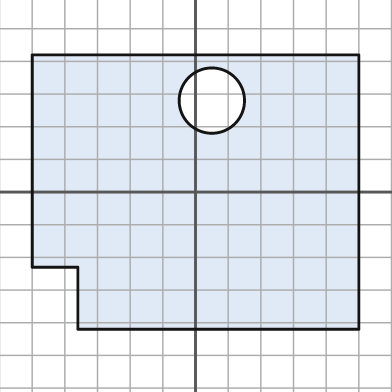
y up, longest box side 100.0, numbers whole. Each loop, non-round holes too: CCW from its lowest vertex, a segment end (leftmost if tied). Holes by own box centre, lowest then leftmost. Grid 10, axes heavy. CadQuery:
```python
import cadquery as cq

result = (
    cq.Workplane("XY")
    .moveTo(-36.0, -42.0)
    .lineTo(50.0, -42.0)
    .lineTo(50.0, 42.0)
    .lineTo(-50.0, 42.0)
    .lineTo(-50.0, -23.0)
    .lineTo(-36.0, -23.0)
    .close()
    .moveTo(5.0, 28.0)
    .circle(10.0)
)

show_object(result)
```